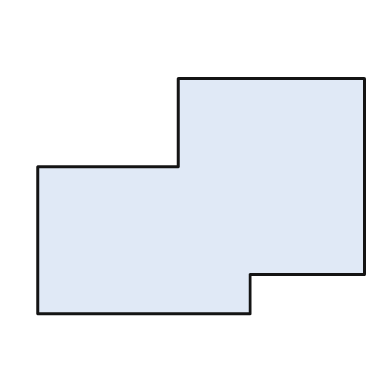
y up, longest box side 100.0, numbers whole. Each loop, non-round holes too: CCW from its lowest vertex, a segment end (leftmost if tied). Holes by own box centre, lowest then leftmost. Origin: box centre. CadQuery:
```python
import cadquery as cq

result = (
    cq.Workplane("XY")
    .moveTo(-50.0, -36.0)
    .lineTo(15.0, -36.0)
    .lineTo(15.0, -24.0)
    .lineTo(50.0, -24.0)
    .lineTo(50.0, 36.0)
    .lineTo(-7.0, 36.0)
    .lineTo(-7.0, 9.0)
    .lineTo(-50.0, 9.0)
    .close()
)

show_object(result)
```